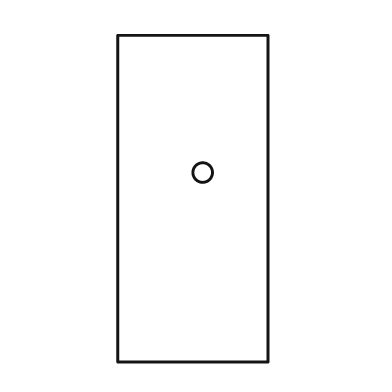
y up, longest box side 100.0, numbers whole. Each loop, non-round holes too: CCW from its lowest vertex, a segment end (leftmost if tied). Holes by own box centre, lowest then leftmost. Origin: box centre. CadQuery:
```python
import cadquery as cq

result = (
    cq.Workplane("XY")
    .moveTo(-23.0, -50.0)
    .lineTo(23.0, -50.0)
    .lineTo(23.0, 50.0)
    .lineTo(-23.0, 50.0)
    .close()
    .moveTo(3.0, 8.0)
    .circle(3.0)
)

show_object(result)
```